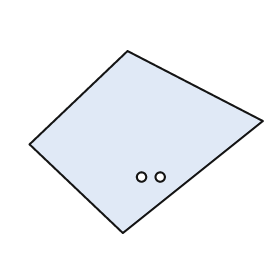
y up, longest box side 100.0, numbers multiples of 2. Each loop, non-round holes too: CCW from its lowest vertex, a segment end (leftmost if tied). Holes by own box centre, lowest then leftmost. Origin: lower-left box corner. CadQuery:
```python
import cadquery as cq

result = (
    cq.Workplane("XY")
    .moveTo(40.0, 0.0)
    .lineTo(100.0, 48.0)
    .lineTo(42.0, 78.0)
    .lineTo(0.0, 38.0)
    .close()
    .moveTo(48.0, 24.0)
    .circle(2.0)
    .moveTo(56.0, 24.0)
    .circle(2.0)
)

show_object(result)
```